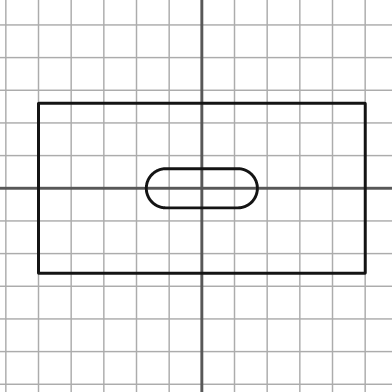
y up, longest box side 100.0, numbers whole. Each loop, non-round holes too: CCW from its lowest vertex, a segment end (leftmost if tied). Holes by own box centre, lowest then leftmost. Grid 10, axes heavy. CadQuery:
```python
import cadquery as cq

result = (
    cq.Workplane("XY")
    .moveTo(-50.0, -26.0)
    .lineTo(50.0, -26.0)
    .lineTo(50.0, 26.0)
    .lineTo(-50.0, 26.0)
    .close()
    .moveTo(-11.0, -6.0)
    .lineTo(11.0, -6.0)
    .threePointArc((17.0, 0.0), (11.0, 6.0))
    .lineTo(-11.0, 6.0)
    .threePointArc((-17.0, 0.0), (-11.0, -6.0))
    .close()
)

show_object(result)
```